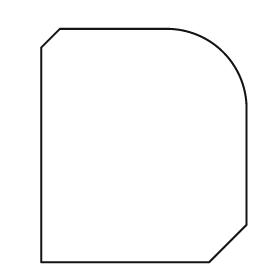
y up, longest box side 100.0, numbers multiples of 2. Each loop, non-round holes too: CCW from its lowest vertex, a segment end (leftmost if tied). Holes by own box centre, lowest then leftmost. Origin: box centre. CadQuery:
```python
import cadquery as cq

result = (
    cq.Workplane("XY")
    .moveTo(-44.0, -50.0)
    .lineTo(28.0, -50.0)
    .lineTo(44.0, -34.0)
    .lineTo(44.0, 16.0)
    .threePointArc((34.0, 40.0), (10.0, 50.0))
    .lineTo(-36.0, 50.0)
    .lineTo(-44.0, 42.0)
    .close()
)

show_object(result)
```